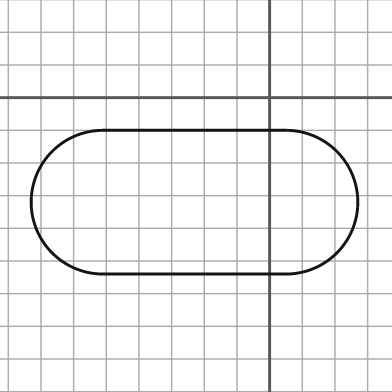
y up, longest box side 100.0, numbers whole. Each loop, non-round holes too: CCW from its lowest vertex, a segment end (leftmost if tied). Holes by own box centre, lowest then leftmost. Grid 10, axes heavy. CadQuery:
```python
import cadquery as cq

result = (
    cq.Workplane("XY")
    .moveTo(-51.0, -54.0)
    .lineTo(5.0, -54.0)
    .threePointArc((27.0, -32.0), (5.0, -10.0))
    .lineTo(-51.0, -10.0)
    .threePointArc((-73.0, -32.0), (-51.0, -54.0))
    .close()
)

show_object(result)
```